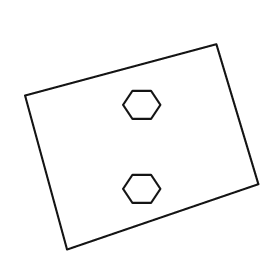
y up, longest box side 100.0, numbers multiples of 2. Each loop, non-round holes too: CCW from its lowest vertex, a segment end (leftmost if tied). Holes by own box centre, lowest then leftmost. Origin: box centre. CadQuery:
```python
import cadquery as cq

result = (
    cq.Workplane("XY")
    .moveTo(-32.0, -44.0)
    .lineTo(50.0, -16.0)
    .lineTo(32.0, 44.0)
    .lineTo(-50.0, 22.0)
    .close()
    .moveTo(-4.0, -24.0)
    .lineTo(4.0, -24.0)
    .lineTo(8.0, -18.0)
    .lineTo(4.0, -12.0)
    .lineTo(-4.0, -12.0)
    .lineTo(-8.0, -18.0)
    .close()
    .moveTo(-4.0, 12.0)
    .lineTo(4.0, 12.0)
    .lineTo(8.0, 18.0)
    .lineTo(4.0, 24.0)
    .lineTo(-4.0, 24.0)
    .lineTo(-8.0, 18.0)
    .close()
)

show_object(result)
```